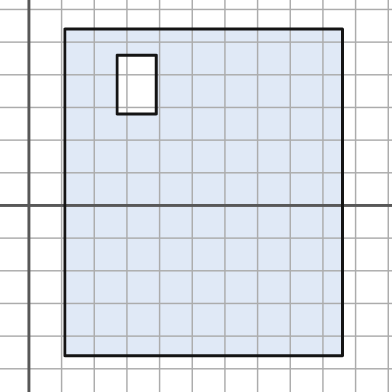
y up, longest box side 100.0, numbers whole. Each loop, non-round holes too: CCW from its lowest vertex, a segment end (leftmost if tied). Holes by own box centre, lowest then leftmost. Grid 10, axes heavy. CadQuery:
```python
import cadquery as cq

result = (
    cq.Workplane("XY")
    .moveTo(11.0, -46.0)
    .lineTo(96.0, -46.0)
    .lineTo(96.0, 54.0)
    .lineTo(11.0, 54.0)
    .close()
    .moveTo(27.0, 28.0)
    .lineTo(39.0, 28.0)
    .lineTo(39.0, 46.0)
    .lineTo(27.0, 46.0)
    .close()
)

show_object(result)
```